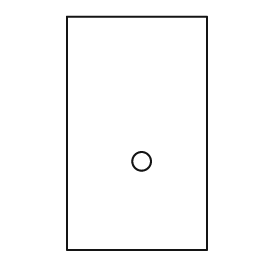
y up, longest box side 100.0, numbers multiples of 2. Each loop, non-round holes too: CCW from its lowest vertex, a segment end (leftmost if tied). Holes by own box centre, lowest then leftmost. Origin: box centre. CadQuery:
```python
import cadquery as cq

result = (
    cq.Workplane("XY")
    .moveTo(-30.0, -50.0)
    .lineTo(30.0, -50.0)
    .lineTo(30.0, 50.0)
    .lineTo(-30.0, 50.0)
    .close()
    .moveTo(2.0, -12.0)
    .circle(4.0)
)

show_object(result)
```